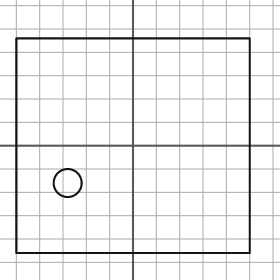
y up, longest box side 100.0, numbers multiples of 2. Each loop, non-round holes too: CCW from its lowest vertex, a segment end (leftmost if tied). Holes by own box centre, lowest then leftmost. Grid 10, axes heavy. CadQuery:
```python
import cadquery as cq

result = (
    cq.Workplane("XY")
    .moveTo(-50.0, -46.0)
    .lineTo(50.0, -46.0)
    .lineTo(50.0, 46.0)
    .lineTo(-50.0, 46.0)
    .close()
    .moveTo(-28.0, -16.0)
    .circle(6.0)
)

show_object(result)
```